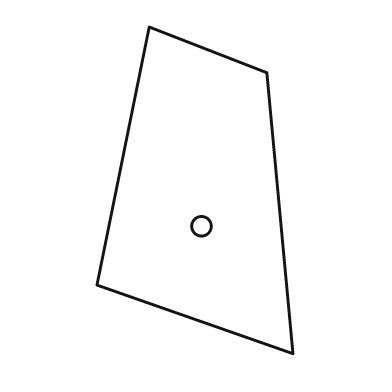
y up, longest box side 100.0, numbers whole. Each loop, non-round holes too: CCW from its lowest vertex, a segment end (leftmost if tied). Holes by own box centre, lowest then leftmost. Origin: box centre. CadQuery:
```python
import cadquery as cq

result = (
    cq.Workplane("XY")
    .moveTo(30.0, -50.0)
    .lineTo(22.0, 36.0)
    .lineTo(-14.0, 50.0)
    .lineTo(-30.0, -29.0)
    .close()
    .moveTo(2.0, -11.0)
    .circle(3.0)
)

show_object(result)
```